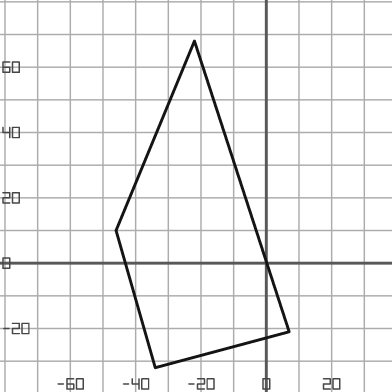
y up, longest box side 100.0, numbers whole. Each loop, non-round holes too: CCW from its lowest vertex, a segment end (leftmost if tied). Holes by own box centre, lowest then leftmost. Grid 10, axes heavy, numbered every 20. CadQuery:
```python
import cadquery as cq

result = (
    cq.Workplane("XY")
    .moveTo(-34.0, -32.0)
    .lineTo(7.0, -21.0)
    .lineTo(-22.0, 68.0)
    .lineTo(-46.0, 10.0)
    .close()
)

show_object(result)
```